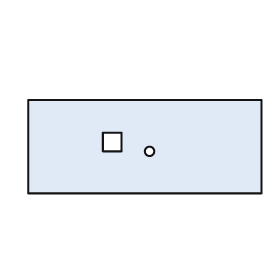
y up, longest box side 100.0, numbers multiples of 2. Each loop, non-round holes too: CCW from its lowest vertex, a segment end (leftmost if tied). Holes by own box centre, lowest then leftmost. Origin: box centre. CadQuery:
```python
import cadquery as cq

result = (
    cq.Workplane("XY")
    .moveTo(-50.0, -20.0)
    .lineTo(50.0, -20.0)
    .lineTo(50.0, 20.0)
    .lineTo(-50.0, 20.0)
    .close()
    .moveTo(2.0, -2.0)
    .circle(2.0)
    .moveTo(-18.0, -2.0)
    .lineTo(-10.0, -2.0)
    .lineTo(-10.0, 6.0)
    .lineTo(-18.0, 6.0)
    .close()
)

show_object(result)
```